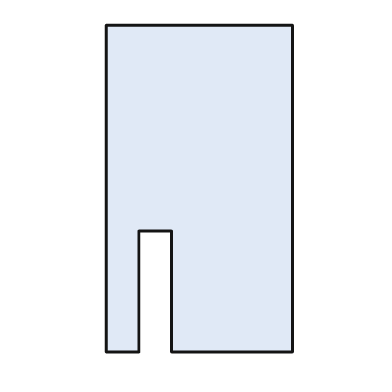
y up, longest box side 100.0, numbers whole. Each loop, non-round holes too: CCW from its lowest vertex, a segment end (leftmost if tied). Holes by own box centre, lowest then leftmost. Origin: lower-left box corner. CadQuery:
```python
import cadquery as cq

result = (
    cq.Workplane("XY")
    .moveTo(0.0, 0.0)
    .lineTo(10.0, 0.0)
    .lineTo(10.0, 37.0)
    .lineTo(20.0, 37.0)
    .lineTo(20.0, 0.0)
    .lineTo(57.0, 0.0)
    .lineTo(57.0, 100.0)
    .lineTo(0.0, 100.0)
    .close()
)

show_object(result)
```